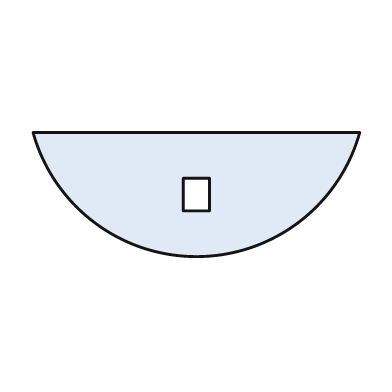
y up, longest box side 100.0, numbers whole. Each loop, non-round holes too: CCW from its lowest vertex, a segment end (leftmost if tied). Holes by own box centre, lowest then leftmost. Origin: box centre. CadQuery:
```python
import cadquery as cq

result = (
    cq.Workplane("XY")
    .moveTo(-50.0, 19.0)
    .threePointArc((0.0, -19.0), (50.0, 19.0))
    .close()
    .moveTo(-4.0, -5.0)
    .lineTo(4.0, -5.0)
    .lineTo(4.0, 5.0)
    .lineTo(-4.0, 5.0)
    .close()
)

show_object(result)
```